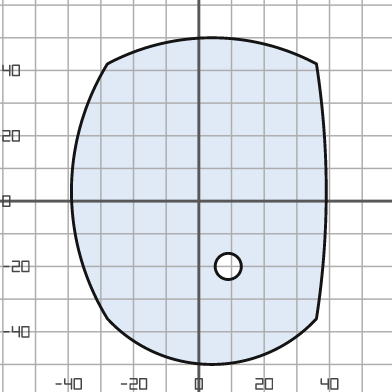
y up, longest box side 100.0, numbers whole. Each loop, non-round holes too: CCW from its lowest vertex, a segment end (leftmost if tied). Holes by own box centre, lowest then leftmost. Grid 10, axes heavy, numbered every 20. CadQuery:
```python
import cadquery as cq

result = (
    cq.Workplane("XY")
    .moveTo(-28.0, -36.0)
    .threePointArc((4.0, -50.0), (36.0, -36.0))
    .threePointArc((39.0, 3.0), (36.0, 42.0))
    .threePointArc((4.0, 50.0), (-28.0, 42.0))
    .threePointArc((-39.0, 3.0), (-28.0, -36.0))
    .close()
    .moveTo(9.0, -20.0)
    .circle(4.0)
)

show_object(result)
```